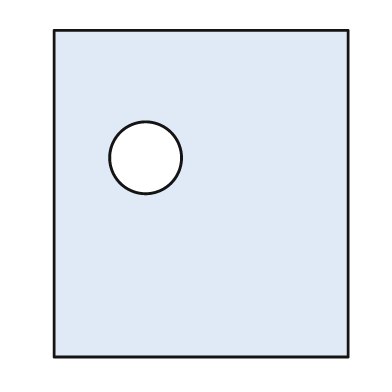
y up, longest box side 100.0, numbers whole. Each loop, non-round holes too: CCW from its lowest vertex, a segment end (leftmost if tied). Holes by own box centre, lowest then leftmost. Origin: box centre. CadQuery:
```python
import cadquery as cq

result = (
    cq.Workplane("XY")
    .moveTo(-45.0, -50.0)
    .lineTo(45.0, -50.0)
    .lineTo(45.0, 50.0)
    .lineTo(-45.0, 50.0)
    .close()
    .moveTo(-17.0, 11.0)
    .circle(11.0)
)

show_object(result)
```